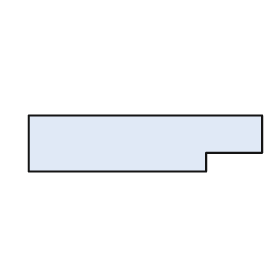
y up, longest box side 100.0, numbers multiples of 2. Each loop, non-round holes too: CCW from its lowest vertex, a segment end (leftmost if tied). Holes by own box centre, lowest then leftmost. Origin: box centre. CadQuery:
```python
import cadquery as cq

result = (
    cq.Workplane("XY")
    .moveTo(-50.0, -12.0)
    .lineTo(26.0, -12.0)
    .lineTo(26.0, -4.0)
    .lineTo(50.0, -4.0)
    .lineTo(50.0, 12.0)
    .lineTo(-50.0, 12.0)
    .close()
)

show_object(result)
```